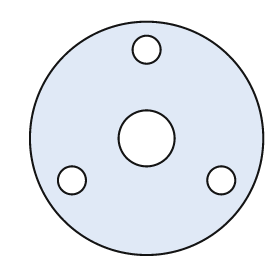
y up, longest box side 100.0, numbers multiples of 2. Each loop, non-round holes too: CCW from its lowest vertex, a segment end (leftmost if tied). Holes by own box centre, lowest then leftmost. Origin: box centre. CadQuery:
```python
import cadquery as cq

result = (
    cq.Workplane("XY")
    .moveTo(0.0, 0.0)
    .circle(50.0)
    .moveTo(-32.0, -18.0)
    .circle(6.0)
    .moveTo(32.0, -18.0)
    .circle(6.0)
    .moveTo(0.0, 0.0)
    .circle(12.0)
    .moveTo(0.0, 38.0)
    .circle(6.0)
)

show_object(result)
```